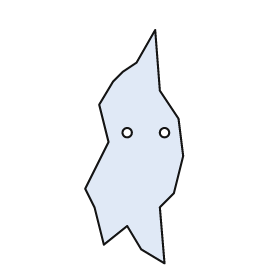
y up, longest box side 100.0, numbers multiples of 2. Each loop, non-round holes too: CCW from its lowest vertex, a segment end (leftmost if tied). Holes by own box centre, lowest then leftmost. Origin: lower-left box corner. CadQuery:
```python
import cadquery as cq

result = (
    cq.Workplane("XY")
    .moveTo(34.0, 0.0)
    .lineTo(32.0, 24.0)
    .lineTo(38.0, 30.0)
    .lineTo(42.0, 46.0)
    .lineTo(40.0, 62.0)
    .lineTo(32.0, 74.0)
    .lineTo(30.0, 100.0)
    .lineTo(22.0, 86.0)
    .lineTo(16.0, 82.0)
    .lineTo(12.0, 78.0)
    .lineTo(6.0, 68.0)
    .lineTo(10.0, 52.0)
    .lineTo(0.0, 32.0)
    .lineTo(4.0, 24.0)
    .lineTo(8.0, 8.0)
    .lineTo(18.0, 16.0)
    .lineTo(24.0, 6.0)
    .close()
    .moveTo(18.0, 56.0)
    .circle(2.0)
    .moveTo(34.0, 56.0)
    .circle(2.0)
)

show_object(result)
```